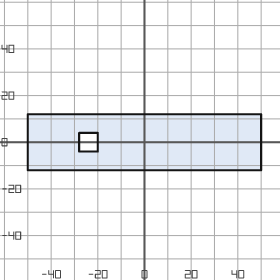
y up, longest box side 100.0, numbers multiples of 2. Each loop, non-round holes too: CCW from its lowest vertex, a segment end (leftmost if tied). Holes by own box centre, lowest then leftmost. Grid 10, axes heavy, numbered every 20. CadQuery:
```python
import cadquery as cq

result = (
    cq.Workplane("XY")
    .moveTo(-50.0, -12.0)
    .lineTo(50.0, -12.0)
    .lineTo(50.0, 12.0)
    .lineTo(-50.0, 12.0)
    .close()
    .moveTo(-28.0, -4.0)
    .lineTo(-20.0, -4.0)
    .lineTo(-20.0, 4.0)
    .lineTo(-28.0, 4.0)
    .close()
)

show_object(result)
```